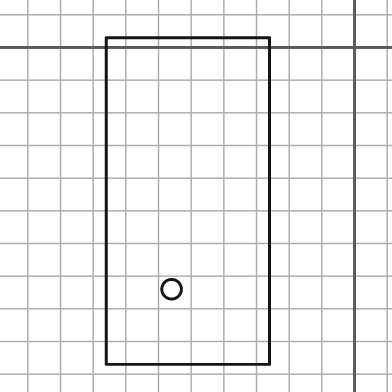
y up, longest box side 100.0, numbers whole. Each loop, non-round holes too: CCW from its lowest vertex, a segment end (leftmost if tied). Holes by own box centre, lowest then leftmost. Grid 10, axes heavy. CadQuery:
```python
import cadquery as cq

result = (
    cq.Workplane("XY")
    .moveTo(-76.0, -97.0)
    .lineTo(-26.0, -97.0)
    .lineTo(-26.0, 3.0)
    .lineTo(-76.0, 3.0)
    .close()
    .moveTo(-56.0, -74.0)
    .circle(3.0)
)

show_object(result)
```